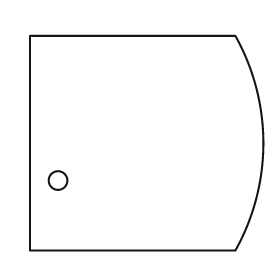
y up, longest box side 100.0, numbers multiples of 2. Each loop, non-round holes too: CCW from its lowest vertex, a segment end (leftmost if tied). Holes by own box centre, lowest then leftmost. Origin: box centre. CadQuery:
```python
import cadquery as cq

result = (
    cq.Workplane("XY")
    .moveTo(-50.0, -46.0)
    .lineTo(38.0, -46.0)
    .threePointArc((50.0, 0.0), (38.0, 46.0))
    .lineTo(-50.0, 46.0)
    .close()
    .moveTo(-38.0, -16.0)
    .circle(4.0)
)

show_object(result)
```